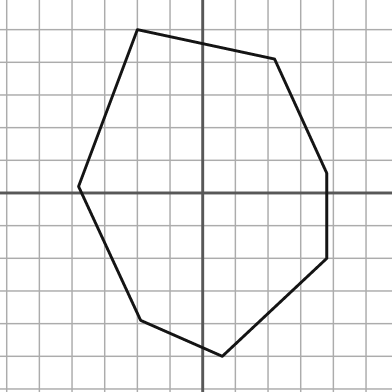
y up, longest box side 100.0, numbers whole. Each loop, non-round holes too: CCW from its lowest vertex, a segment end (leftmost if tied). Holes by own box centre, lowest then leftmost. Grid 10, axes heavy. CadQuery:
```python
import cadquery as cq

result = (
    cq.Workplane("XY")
    .moveTo(6.0, -50.0)
    .lineTo(38.0, -20.0)
    .lineTo(38.0, 6.0)
    .lineTo(22.0, 41.0)
    .lineTo(-20.0, 50.0)
    .lineTo(-38.0, 2.0)
    .lineTo(-19.0, -39.0)
    .close()
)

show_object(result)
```